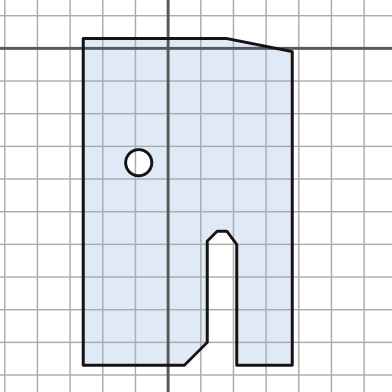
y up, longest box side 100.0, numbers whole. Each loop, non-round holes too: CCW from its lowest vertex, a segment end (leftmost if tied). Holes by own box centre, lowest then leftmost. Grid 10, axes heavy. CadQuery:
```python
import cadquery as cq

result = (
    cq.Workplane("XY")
    .moveTo(-26.0, -97.0)
    .lineTo(5.0, -97.0)
    .lineTo(12.0, -90.0)
    .lineTo(12.0, -59.0)
    .lineTo(15.0, -56.0)
    .lineTo(18.0, -56.0)
    .lineTo(21.0, -60.0)
    .lineTo(21.0, -97.0)
    .lineTo(38.0, -97.0)
    .lineTo(38.0, -1.0)
    .lineTo(18.0, 3.0)
    .lineTo(-26.0, 3.0)
    .close()
    .moveTo(-9.0, -35.0)
    .circle(4.0)
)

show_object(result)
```